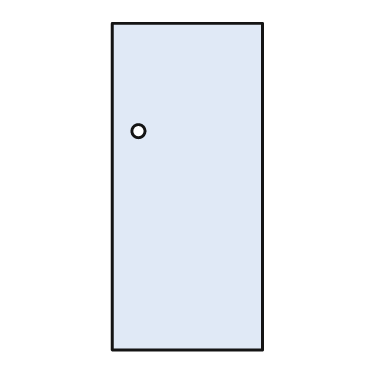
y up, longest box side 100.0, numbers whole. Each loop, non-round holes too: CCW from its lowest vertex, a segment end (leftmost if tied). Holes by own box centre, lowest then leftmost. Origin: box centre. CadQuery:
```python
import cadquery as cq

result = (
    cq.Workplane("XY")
    .moveTo(-23.0, -50.0)
    .lineTo(23.0, -50.0)
    .lineTo(23.0, 50.0)
    .lineTo(-23.0, 50.0)
    .close()
    .moveTo(-15.0, 17.0)
    .circle(2.0)
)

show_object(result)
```